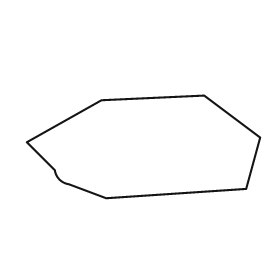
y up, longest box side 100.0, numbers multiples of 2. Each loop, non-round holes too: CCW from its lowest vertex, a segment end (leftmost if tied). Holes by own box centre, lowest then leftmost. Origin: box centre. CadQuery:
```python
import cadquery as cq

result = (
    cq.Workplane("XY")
    .moveTo(-16.0, -22.0)
    .lineTo(44.0, -18.0)
    .lineTo(50.0, 4.0)
    .lineTo(26.0, 22.0)
    .lineTo(-18.0, 20.0)
    .lineTo(-50.0, 2.0)
    .lineTo(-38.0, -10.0)
    .threePointArc((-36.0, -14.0), (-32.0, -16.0))
    .close()
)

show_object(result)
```